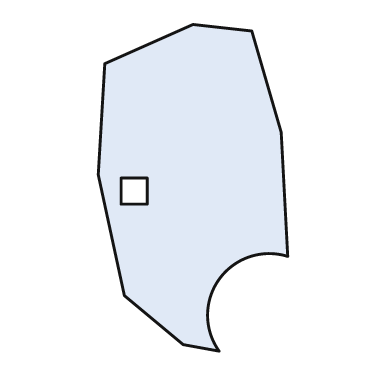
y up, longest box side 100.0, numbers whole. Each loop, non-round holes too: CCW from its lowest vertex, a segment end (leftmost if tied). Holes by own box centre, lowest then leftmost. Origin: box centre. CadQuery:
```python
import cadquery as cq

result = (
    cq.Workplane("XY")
    .moveTo(8.0, -50.0)
    .threePointArc((8.0, -28.0), (29.0, -21.0))
    .lineTo(27.0, 17.0)
    .lineTo(18.0, 48.0)
    .lineTo(0.0, 50.0)
    .lineTo(-27.0, 38.0)
    .lineTo(-29.0, 4.0)
    .lineTo(-21.0, -33.0)
    .lineTo(-3.0, -48.0)
    .close()
    .moveTo(-22.0, -5.0)
    .lineTo(-14.0, -5.0)
    .lineTo(-14.0, 3.0)
    .lineTo(-22.0, 3.0)
    .close()
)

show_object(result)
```